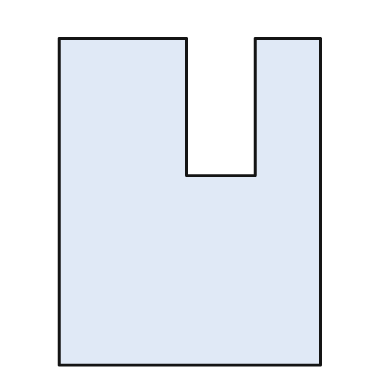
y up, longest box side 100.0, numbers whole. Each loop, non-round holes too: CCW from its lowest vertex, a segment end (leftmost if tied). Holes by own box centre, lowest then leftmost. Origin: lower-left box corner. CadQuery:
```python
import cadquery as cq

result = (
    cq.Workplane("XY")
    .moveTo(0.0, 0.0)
    .lineTo(80.0, 0.0)
    .lineTo(80.0, 100.0)
    .lineTo(60.0, 100.0)
    .lineTo(60.0, 58.0)
    .lineTo(39.0, 58.0)
    .lineTo(39.0, 100.0)
    .lineTo(0.0, 100.0)
    .close()
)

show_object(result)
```